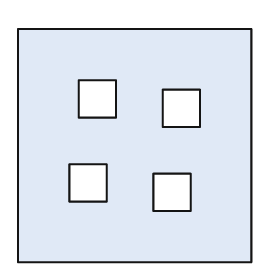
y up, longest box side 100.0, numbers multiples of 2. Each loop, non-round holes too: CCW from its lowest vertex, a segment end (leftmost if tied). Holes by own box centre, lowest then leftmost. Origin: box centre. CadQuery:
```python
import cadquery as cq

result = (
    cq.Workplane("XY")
    .moveTo(-50.0, -50.0)
    .lineTo(50.0, -50.0)
    .lineTo(50.0, 50.0)
    .lineTo(-50.0, 50.0)
    .close()
    .moveTo(8.0, -28.0)
    .lineTo(24.0, -28.0)
    .lineTo(24.0, -12.0)
    .lineTo(8.0, -12.0)
    .close()
    .moveTo(-28.0, -24.0)
    .lineTo(-12.0, -24.0)
    .lineTo(-12.0, -8.0)
    .lineTo(-28.0, -8.0)
    .close()
    .moveTo(12.0, 8.0)
    .lineTo(28.0, 8.0)
    .lineTo(28.0, 24.0)
    .lineTo(12.0, 24.0)
    .close()
    .moveTo(-24.0, 12.0)
    .lineTo(-8.0, 12.0)
    .lineTo(-8.0, 28.0)
    .lineTo(-24.0, 28.0)
    .close()
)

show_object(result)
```